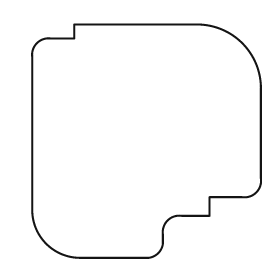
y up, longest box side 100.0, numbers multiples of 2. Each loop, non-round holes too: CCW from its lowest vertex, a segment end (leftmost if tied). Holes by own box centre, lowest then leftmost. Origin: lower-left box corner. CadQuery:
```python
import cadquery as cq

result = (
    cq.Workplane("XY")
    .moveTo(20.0, 0.0)
    .lineTo(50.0, 0.0)
    .threePointArc((54.0, 2.0), (56.0, 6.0))
    .lineTo(56.0, 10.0)
    .threePointArc((58.0, 16.0), (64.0, 18.0))
    .lineTo(76.0, 18.0)
    .lineTo(76.0, 26.0)
    .lineTo(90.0, 26.0)
    .threePointArc((96.0, 28.0), (98.0, 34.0))
    .lineTo(98.0, 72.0)
    .threePointArc((90.0, 92.0), (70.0, 100.0))
    .lineTo(18.0, 100.0)
    .lineTo(18.0, 94.0)
    .lineTo(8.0, 94.0)
    .threePointArc((2.0, 92.0), (0.0, 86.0))
    .lineTo(0.0, 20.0)
    .threePointArc((6.0, 6.0), (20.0, 0.0))
    .close()
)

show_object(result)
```